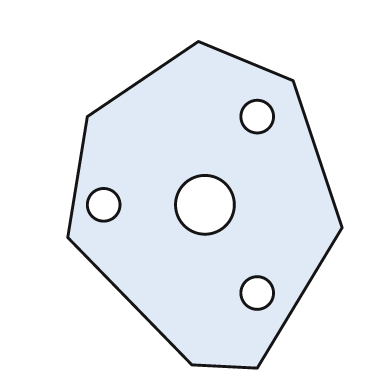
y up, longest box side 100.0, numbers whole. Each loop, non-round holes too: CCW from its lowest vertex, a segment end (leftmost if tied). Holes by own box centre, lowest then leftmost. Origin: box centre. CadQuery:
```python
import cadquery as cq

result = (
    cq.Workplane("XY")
    .moveTo(16.0, -50.0)
    .lineTo(42.0, -7.0)
    .lineTo(27.0, 38.0)
    .lineTo(-2.0, 50.0)
    .lineTo(-36.0, 27.0)
    .lineTo(-42.0, -10.0)
    .lineTo(-4.0, -49.0)
    .close()
    .moveTo(16.0, -27.0)
    .circle(5.0)
    .moveTo(-31.0, 0.0)
    .circle(5.0)
    .moveTo(0.0, 0.0)
    .circle(9.0)
    .moveTo(16.0, 27.0)
    .circle(5.0)
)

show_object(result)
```